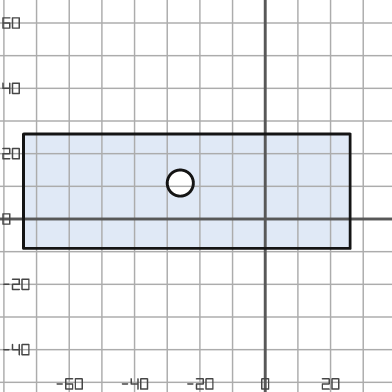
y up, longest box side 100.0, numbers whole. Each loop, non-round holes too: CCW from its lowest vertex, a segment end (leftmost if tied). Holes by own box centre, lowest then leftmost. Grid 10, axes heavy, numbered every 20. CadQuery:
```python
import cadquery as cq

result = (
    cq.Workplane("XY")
    .moveTo(-74.0, -9.0)
    .lineTo(26.0, -9.0)
    .lineTo(26.0, 26.0)
    .lineTo(-74.0, 26.0)
    .close()
    .moveTo(-26.0, 11.0)
    .circle(4.0)
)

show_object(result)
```